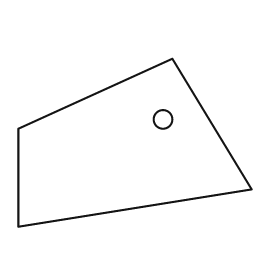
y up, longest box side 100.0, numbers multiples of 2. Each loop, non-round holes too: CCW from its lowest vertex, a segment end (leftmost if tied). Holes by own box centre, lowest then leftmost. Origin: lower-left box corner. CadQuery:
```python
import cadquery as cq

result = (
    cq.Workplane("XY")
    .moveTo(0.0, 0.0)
    .lineTo(100.0, 16.0)
    .lineTo(66.0, 72.0)
    .lineTo(0.0, 42.0)
    .close()
    .moveTo(62.0, 46.0)
    .circle(4.0)
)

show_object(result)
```